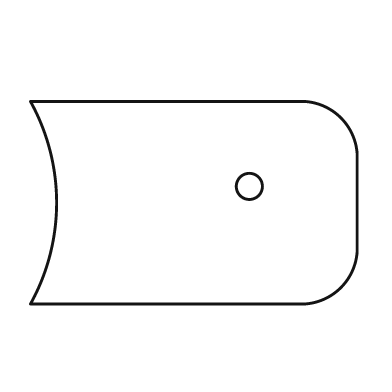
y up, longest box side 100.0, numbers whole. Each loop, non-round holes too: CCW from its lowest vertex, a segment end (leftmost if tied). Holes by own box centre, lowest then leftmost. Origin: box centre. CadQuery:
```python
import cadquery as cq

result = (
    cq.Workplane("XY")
    .moveTo(-50.0, -31.0)
    .lineTo(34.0, -31.0)
    .threePointArc((45.0, -26.0), (50.0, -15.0))
    .lineTo(50.0, 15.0)
    .threePointArc((45.0, 26.0), (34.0, 31.0))
    .lineTo(-50.0, 31.0)
    .threePointArc((-42.0, 0.0), (-50.0, -31.0))
    .close()
    .moveTo(17.0, 5.0)
    .circle(4.0)
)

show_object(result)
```